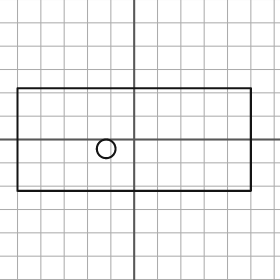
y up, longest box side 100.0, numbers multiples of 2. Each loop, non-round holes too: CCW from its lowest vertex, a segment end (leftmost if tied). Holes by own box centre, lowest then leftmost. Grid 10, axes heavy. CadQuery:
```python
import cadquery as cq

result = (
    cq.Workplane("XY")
    .moveTo(-50.0, -22.0)
    .lineTo(50.0, -22.0)
    .lineTo(50.0, 22.0)
    .lineTo(-50.0, 22.0)
    .close()
    .moveTo(-12.0, -4.0)
    .circle(4.0)
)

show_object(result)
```